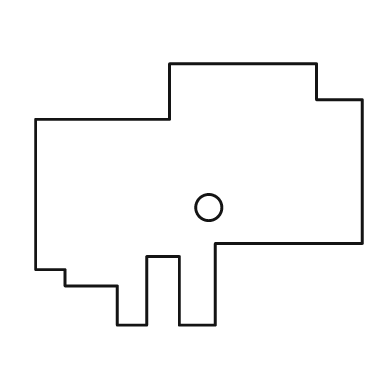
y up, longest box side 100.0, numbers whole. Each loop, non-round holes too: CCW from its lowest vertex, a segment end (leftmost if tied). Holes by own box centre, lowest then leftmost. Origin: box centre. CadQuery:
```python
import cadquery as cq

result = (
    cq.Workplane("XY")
    .moveTo(-25.0, -40.0)
    .lineTo(-16.0, -40.0)
    .lineTo(-16.0, -19.0)
    .lineTo(-6.0, -19.0)
    .lineTo(-6.0, -40.0)
    .lineTo(5.0, -40.0)
    .lineTo(5.0, -15.0)
    .lineTo(50.0, -15.0)
    .lineTo(50.0, 29.0)
    .lineTo(36.0, 29.0)
    .lineTo(36.0, 40.0)
    .lineTo(-9.0, 40.0)
    .lineTo(-9.0, 23.0)
    .lineTo(-50.0, 23.0)
    .lineTo(-50.0, -23.0)
    .lineTo(-41.0, -23.0)
    .lineTo(-41.0, -28.0)
    .lineTo(-25.0, -28.0)
    .close()
    .moveTo(3.0, -4.0)
    .circle(4.0)
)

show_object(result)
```